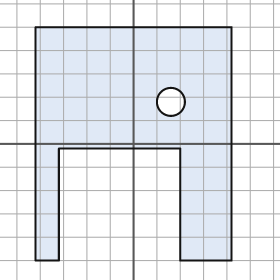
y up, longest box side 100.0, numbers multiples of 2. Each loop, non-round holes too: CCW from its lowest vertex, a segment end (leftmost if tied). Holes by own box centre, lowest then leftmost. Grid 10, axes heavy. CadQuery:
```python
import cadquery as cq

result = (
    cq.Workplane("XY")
    .moveTo(-42.0, -50.0)
    .lineTo(-32.0, -50.0)
    .lineTo(-32.0, -2.0)
    .lineTo(20.0, -2.0)
    .lineTo(20.0, -50.0)
    .lineTo(42.0, -50.0)
    .lineTo(42.0, 50.0)
    .lineTo(-42.0, 50.0)
    .close()
    .moveTo(16.0, 18.0)
    .circle(6.0)
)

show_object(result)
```